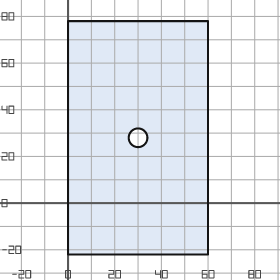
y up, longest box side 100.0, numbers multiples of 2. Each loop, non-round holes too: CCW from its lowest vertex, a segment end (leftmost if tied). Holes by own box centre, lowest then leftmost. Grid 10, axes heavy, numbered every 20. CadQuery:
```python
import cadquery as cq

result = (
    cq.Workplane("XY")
    .moveTo(0.0, -22.0)
    .lineTo(60.0, -22.0)
    .lineTo(60.0, 78.0)
    .lineTo(0.0, 78.0)
    .close()
    .moveTo(30.0, 28.0)
    .circle(4.0)
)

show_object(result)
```